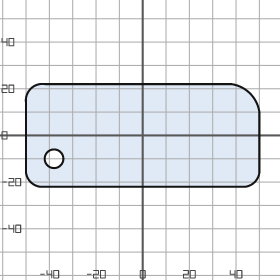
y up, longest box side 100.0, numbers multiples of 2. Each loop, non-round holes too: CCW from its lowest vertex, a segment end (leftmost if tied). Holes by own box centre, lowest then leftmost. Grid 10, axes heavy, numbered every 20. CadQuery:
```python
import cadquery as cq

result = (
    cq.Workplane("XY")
    .moveTo(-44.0, -22.0)
    .lineTo(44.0, -22.0)
    .threePointArc((48.0, -20.0), (50.0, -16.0))
    .lineTo(50.0, 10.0)
    .threePointArc((46.0, 18.0), (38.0, 22.0))
    .lineTo(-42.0, 22.0)
    .threePointArc((-48.0, 20.0), (-50.0, 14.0))
    .lineTo(-50.0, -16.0)
    .threePointArc((-48.0, -20.0), (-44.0, -22.0))
    .close()
    .moveTo(-38.0, -10.0)
    .circle(4.0)
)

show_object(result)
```